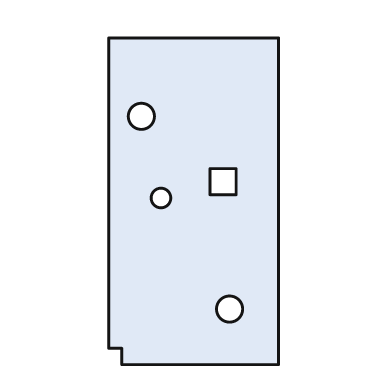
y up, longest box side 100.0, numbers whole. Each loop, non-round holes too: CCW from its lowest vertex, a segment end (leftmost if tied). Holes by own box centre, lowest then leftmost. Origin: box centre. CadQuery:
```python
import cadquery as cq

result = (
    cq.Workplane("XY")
    .moveTo(-22.0, -50.0)
    .lineTo(26.0, -50.0)
    .lineTo(26.0, 50.0)
    .lineTo(-26.0, 50.0)
    .lineTo(-26.0, -45.0)
    .lineTo(-22.0, -45.0)
    .close()
    .moveTo(11.0, -33.0)
    .circle(4.0)
    .moveTo(-10.0, 1.0)
    .circle(3.0)
    .moveTo(5.0, 2.0)
    .lineTo(13.0, 2.0)
    .lineTo(13.0, 10.0)
    .lineTo(5.0, 10.0)
    .close()
    .moveTo(-16.0, 26.0)
    .circle(4.0)
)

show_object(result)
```